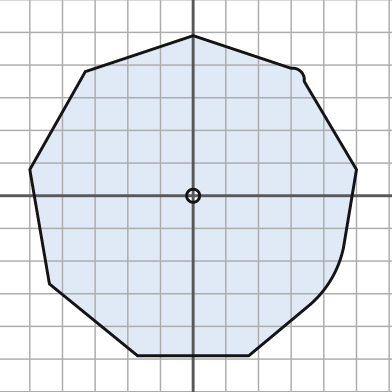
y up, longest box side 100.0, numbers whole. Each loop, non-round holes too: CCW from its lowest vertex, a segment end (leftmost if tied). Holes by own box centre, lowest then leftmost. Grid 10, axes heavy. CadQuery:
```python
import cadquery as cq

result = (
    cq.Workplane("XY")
    .moveTo(-17.0, -49.0)
    .lineTo(17.0, -49.0)
    .lineTo(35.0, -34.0)
    .threePointArc((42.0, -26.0), (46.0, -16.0))
    .lineTo(50.0, 8.0)
    .lineTo(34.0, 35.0)
    .threePointArc((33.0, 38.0), (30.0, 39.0))
    .lineTo(0.0, 49.0)
    .lineTo(-33.0, 38.0)
    .lineTo(-50.0, 8.0)
    .lineTo(-44.0, -27.0)
    .close()
    .moveTo(0.0, 0.0)
    .circle(2.0)
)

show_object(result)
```